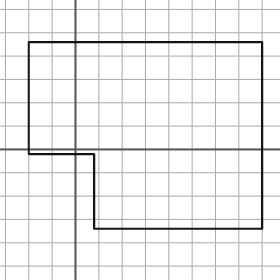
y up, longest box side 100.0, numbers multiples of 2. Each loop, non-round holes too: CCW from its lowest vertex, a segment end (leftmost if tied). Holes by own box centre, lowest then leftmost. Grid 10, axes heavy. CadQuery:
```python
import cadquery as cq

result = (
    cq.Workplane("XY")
    .moveTo(8.0, -34.0)
    .lineTo(80.0, -34.0)
    .lineTo(80.0, 46.0)
    .lineTo(-20.0, 46.0)
    .lineTo(-20.0, -2.0)
    .lineTo(8.0, -2.0)
    .close()
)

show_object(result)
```